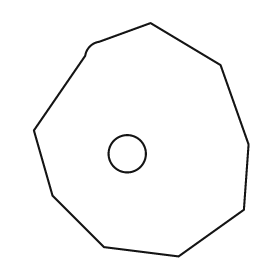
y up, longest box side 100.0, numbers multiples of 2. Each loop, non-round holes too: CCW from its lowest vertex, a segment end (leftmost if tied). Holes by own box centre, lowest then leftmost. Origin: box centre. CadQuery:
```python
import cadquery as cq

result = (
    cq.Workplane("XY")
    .moveTo(16.0, -50.0)
    .lineTo(44.0, -30.0)
    .lineTo(46.0, -2.0)
    .lineTo(34.0, 32.0)
    .lineTo(4.0, 50.0)
    .lineTo(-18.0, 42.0)
    .threePointArc((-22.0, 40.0), (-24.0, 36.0))
    .lineTo(-46.0, 4.0)
    .lineTo(-38.0, -24.0)
    .lineTo(-16.0, -46.0)
    .close()
    .moveTo(-6.0, -6.0)
    .circle(8.0)
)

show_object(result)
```